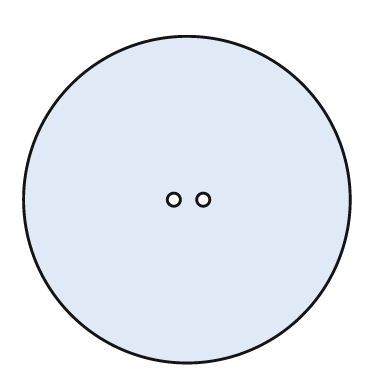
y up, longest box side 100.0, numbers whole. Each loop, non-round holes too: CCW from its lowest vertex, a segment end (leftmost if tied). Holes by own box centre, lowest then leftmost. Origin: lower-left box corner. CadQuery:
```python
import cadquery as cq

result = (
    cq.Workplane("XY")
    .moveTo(50.0, 50.0)
    .circle(50.0)
    .moveTo(46.0, 50.0)
    .circle(2.0)
    .moveTo(55.0, 50.0)
    .circle(2.0)
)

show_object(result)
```